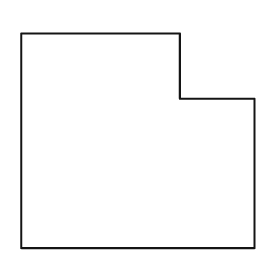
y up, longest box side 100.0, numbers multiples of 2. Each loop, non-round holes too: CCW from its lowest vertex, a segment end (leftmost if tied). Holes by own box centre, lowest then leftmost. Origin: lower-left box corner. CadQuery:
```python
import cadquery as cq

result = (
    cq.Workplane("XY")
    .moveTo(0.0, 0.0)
    .lineTo(100.0, 0.0)
    .lineTo(100.0, 64.0)
    .lineTo(68.0, 64.0)
    .lineTo(68.0, 92.0)
    .lineTo(0.0, 92.0)
    .close()
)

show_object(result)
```